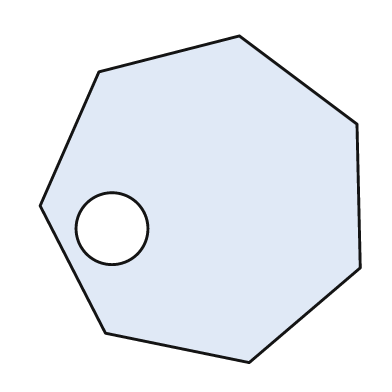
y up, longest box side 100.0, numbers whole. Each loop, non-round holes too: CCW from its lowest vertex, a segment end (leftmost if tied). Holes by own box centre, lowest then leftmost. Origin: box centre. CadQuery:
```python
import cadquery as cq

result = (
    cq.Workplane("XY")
    .moveTo(15.0, -50.0)
    .lineTo(49.0, -21.0)
    .lineTo(48.0, 23.0)
    .lineTo(12.0, 50.0)
    .lineTo(-31.0, 39.0)
    .lineTo(-49.0, -2.0)
    .lineTo(-29.0, -41.0)
    .close()
    .moveTo(-27.0, -9.0)
    .circle(11.0)
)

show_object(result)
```